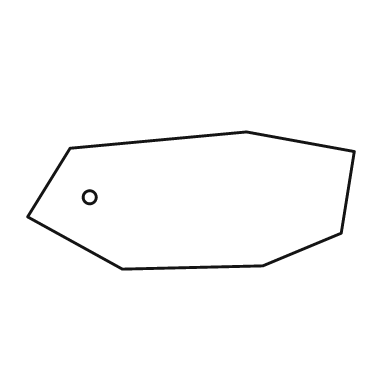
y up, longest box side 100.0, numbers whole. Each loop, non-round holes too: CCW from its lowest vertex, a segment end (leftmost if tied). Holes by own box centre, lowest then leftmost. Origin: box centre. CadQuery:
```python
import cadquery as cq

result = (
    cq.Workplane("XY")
    .moveTo(-21.0, -21.0)
    .lineTo(22.0, -20.0)
    .lineTo(46.0, -10.0)
    .lineTo(50.0, 15.0)
    .lineTo(17.0, 21.0)
    .lineTo(-37.0, 16.0)
    .lineTo(-50.0, -5.0)
    .close()
    .moveTo(-31.0, 1.0)
    .circle(2.0)
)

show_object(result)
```